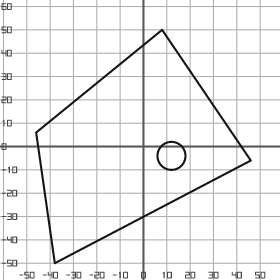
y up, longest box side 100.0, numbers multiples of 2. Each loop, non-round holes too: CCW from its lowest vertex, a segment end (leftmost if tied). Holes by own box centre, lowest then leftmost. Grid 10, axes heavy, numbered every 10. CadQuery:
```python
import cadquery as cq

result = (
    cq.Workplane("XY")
    .moveTo(-38.0, -50.0)
    .lineTo(46.0, -6.0)
    .lineTo(8.0, 50.0)
    .lineTo(-46.0, 6.0)
    .close()
    .moveTo(12.0, -4.0)
    .circle(6.0)
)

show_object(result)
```